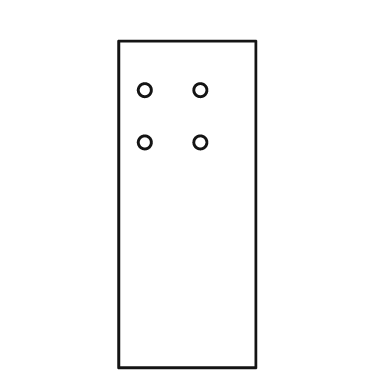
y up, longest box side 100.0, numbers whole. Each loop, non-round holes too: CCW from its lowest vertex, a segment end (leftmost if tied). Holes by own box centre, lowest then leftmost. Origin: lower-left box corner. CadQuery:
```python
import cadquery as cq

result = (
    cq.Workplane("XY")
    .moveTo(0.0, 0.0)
    .lineTo(42.0, 0.0)
    .lineTo(42.0, 100.0)
    .lineTo(0.0, 100.0)
    .close()
    .moveTo(8.0, 69.0)
    .circle(2.0)
    .moveTo(25.0, 69.0)
    .circle(2.0)
    .moveTo(8.0, 85.0)
    .circle(2.0)
    .moveTo(25.0, 85.0)
    .circle(2.0)
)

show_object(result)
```